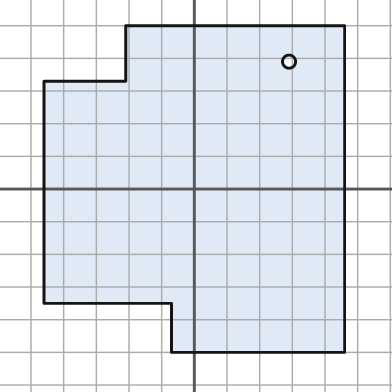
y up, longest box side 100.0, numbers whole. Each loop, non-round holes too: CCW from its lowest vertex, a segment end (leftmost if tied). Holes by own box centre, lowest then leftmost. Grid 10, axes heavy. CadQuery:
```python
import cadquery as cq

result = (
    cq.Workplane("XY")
    .moveTo(-7.0, -50.0)
    .lineTo(46.0, -50.0)
    .lineTo(46.0, 50.0)
    .lineTo(-21.0, 50.0)
    .lineTo(-21.0, 33.0)
    .lineTo(-46.0, 33.0)
    .lineTo(-46.0, -35.0)
    .lineTo(-7.0, -35.0)
    .close()
    .moveTo(29.0, 39.0)
    .circle(2.0)
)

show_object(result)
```